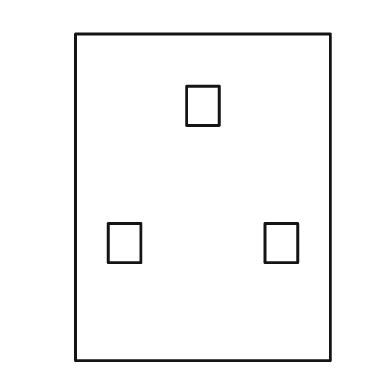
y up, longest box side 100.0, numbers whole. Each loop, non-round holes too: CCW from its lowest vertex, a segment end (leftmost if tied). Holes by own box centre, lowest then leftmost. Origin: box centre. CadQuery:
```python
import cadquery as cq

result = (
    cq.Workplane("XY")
    .moveTo(-39.0, -50.0)
    .lineTo(39.0, -50.0)
    .lineTo(39.0, 50.0)
    .lineTo(-39.0, 50.0)
    .close()
    .moveTo(-29.0, -20.0)
    .lineTo(-19.0, -20.0)
    .lineTo(-19.0, -8.0)
    .lineTo(-29.0, -8.0)
    .close()
    .moveTo(19.0, -20.0)
    .lineTo(29.0, -20.0)
    .lineTo(29.0, -8.0)
    .lineTo(19.0, -8.0)
    .close()
    .moveTo(-5.0, 22.0)
    .lineTo(5.0, 22.0)
    .lineTo(5.0, 34.0)
    .lineTo(-5.0, 34.0)
    .close()
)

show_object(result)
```